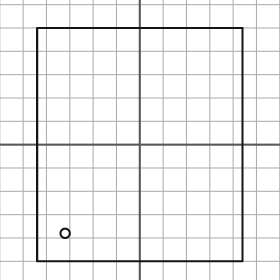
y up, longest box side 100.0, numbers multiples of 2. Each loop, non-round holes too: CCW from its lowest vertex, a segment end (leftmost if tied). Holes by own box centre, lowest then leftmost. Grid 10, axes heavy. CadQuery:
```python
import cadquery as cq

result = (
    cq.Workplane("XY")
    .moveTo(-44.0, -50.0)
    .lineTo(44.0, -50.0)
    .lineTo(44.0, 50.0)
    .lineTo(-44.0, 50.0)
    .close()
    .moveTo(-32.0, -38.0)
    .circle(2.0)
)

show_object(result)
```